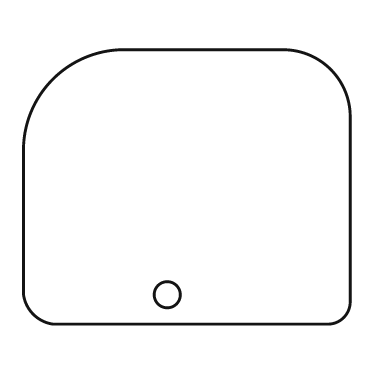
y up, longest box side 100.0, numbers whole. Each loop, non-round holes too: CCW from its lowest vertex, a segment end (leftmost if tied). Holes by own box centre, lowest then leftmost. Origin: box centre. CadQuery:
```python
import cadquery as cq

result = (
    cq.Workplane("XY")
    .moveTo(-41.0, -42.0)
    .lineTo(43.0, -42.0)
    .threePointArc((48.0, -40.0), (50.0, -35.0))
    .lineTo(50.0, 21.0)
    .threePointArc((44.0, 36.0), (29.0, 42.0))
    .lineTo(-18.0, 42.0)
    .threePointArc((-41.0, 33.0), (-50.0, 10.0))
    .lineTo(-50.0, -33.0)
    .threePointArc((-47.0, -39.0), (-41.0, -42.0))
    .close()
    .moveTo(-6.0, -33.0)
    .circle(4.0)
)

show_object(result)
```